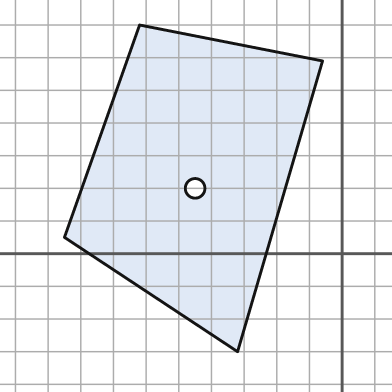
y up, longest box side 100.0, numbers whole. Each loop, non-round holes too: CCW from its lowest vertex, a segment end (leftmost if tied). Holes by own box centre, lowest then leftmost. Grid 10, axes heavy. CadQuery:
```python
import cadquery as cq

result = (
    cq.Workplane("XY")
    .moveTo(-32.0, -30.0)
    .lineTo(-6.0, 59.0)
    .lineTo(-62.0, 70.0)
    .lineTo(-85.0, 5.0)
    .close()
    .moveTo(-45.0, 20.0)
    .circle(3.0)
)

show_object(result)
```